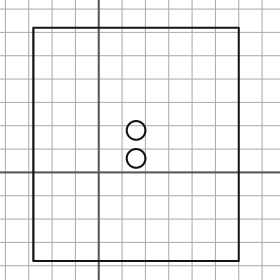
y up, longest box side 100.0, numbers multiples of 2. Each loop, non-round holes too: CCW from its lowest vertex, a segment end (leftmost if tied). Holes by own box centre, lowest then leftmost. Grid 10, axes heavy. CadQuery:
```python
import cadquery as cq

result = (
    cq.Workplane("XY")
    .moveTo(-28.0, -38.0)
    .lineTo(60.0, -38.0)
    .lineTo(60.0, 62.0)
    .lineTo(-28.0, 62.0)
    .close()
    .moveTo(16.0, 6.0)
    .circle(4.0)
    .moveTo(16.0, 18.0)
    .circle(4.0)
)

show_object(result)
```